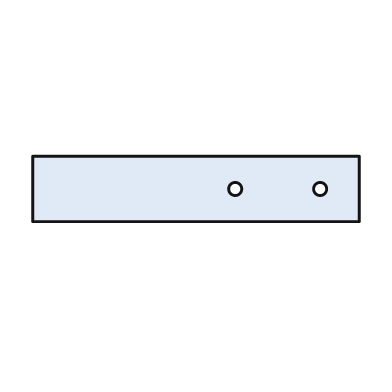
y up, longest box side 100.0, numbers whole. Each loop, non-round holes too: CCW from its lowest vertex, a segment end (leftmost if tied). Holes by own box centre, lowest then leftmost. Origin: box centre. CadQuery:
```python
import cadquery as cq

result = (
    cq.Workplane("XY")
    .moveTo(-50.0, -10.0)
    .lineTo(50.0, -10.0)
    .lineTo(50.0, 10.0)
    .lineTo(-50.0, 10.0)
    .close()
    .moveTo(12.0, 0.0)
    .circle(2.0)
    .moveTo(38.0, 0.0)
    .circle(2.0)
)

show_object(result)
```